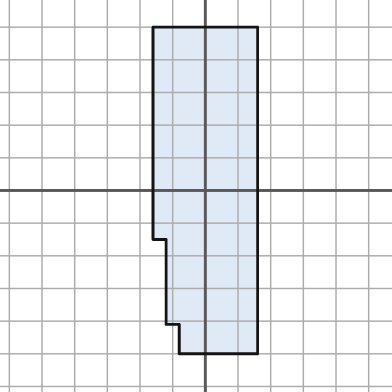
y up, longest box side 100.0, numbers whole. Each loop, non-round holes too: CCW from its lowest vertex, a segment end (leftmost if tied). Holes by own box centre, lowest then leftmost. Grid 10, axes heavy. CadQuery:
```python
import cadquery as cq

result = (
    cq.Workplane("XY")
    .moveTo(-8.0, -50.0)
    .lineTo(16.0, -50.0)
    .lineTo(16.0, 50.0)
    .lineTo(-16.0, 50.0)
    .lineTo(-16.0, -15.0)
    .lineTo(-12.0, -15.0)
    .lineTo(-12.0, -41.0)
    .lineTo(-8.0, -41.0)
    .close()
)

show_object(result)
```